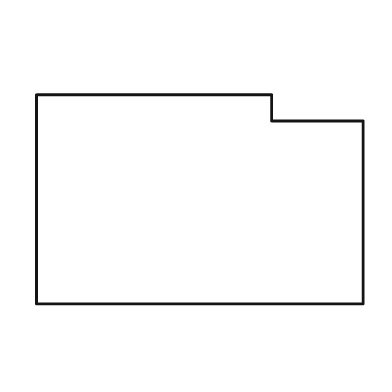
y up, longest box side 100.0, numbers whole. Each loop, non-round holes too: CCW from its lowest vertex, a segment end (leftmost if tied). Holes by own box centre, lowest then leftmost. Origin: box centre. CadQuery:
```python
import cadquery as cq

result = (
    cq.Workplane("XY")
    .moveTo(-50.0, -32.0)
    .lineTo(50.0, -32.0)
    .lineTo(50.0, 24.0)
    .lineTo(22.0, 24.0)
    .lineTo(22.0, 32.0)
    .lineTo(-50.0, 32.0)
    .close()
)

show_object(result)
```